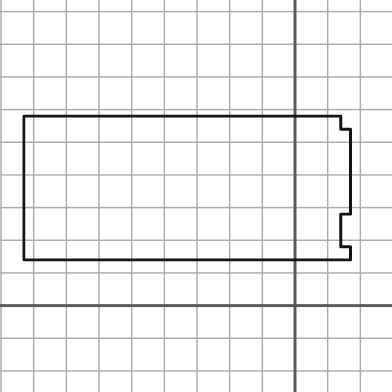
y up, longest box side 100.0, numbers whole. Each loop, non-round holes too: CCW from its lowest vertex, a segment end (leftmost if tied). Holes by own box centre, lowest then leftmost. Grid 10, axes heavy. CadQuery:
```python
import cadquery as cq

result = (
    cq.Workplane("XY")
    .moveTo(-83.0, 14.0)
    .lineTo(17.0, 14.0)
    .lineTo(17.0, 18.0)
    .lineTo(14.0, 18.0)
    .lineTo(14.0, 28.0)
    .lineTo(17.0, 28.0)
    .lineTo(17.0, 54.0)
    .lineTo(14.0, 54.0)
    .lineTo(14.0, 58.0)
    .lineTo(-83.0, 58.0)
    .close()
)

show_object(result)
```